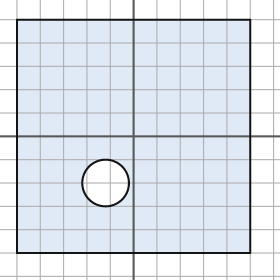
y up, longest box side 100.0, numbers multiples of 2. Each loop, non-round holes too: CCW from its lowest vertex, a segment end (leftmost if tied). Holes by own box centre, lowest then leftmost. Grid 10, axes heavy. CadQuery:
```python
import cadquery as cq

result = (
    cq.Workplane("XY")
    .moveTo(-50.0, -50.0)
    .lineTo(50.0, -50.0)
    .lineTo(50.0, 50.0)
    .lineTo(-50.0, 50.0)
    .close()
    .moveTo(-12.0, -20.0)
    .circle(10.0)
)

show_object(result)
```